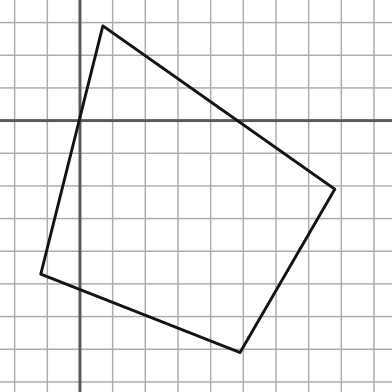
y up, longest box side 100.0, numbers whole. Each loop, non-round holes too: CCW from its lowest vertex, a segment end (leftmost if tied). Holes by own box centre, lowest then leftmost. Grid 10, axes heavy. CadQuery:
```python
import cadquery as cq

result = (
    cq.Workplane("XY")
    .moveTo(49.0, -71.0)
    .lineTo(78.0, -21.0)
    .lineTo(7.0, 29.0)
    .lineTo(-12.0, -47.0)
    .close()
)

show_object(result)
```